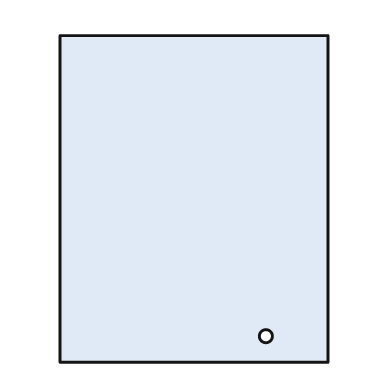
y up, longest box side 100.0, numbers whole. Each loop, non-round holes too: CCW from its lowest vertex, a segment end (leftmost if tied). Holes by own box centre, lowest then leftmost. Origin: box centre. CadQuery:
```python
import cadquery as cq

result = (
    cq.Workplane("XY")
    .moveTo(-41.0, -50.0)
    .lineTo(41.0, -50.0)
    .lineTo(41.0, 50.0)
    .lineTo(-41.0, 50.0)
    .close()
    .moveTo(22.0, -42.0)
    .circle(2.0)
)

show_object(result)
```